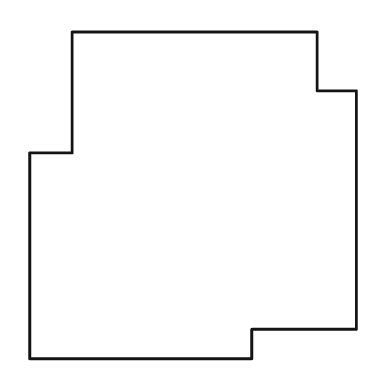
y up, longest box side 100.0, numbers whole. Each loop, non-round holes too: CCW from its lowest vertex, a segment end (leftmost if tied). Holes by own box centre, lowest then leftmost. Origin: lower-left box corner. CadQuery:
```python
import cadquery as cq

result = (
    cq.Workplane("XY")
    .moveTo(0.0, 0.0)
    .lineTo(68.0, 0.0)
    .lineTo(68.0, 9.0)
    .lineTo(100.0, 9.0)
    .lineTo(100.0, 82.0)
    .lineTo(88.0, 82.0)
    .lineTo(88.0, 100.0)
    .lineTo(13.0, 100.0)
    .lineTo(13.0, 63.0)
    .lineTo(0.0, 63.0)
    .close()
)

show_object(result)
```